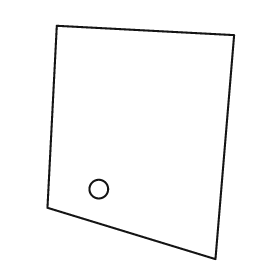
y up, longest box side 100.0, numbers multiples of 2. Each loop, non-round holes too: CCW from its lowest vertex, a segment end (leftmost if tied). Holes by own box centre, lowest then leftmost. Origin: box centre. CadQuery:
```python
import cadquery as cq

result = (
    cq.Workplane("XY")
    .moveTo(32.0, -50.0)
    .lineTo(40.0, 46.0)
    .lineTo(-36.0, 50.0)
    .lineTo(-40.0, -28.0)
    .close()
    .moveTo(-18.0, -20.0)
    .circle(4.0)
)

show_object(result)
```